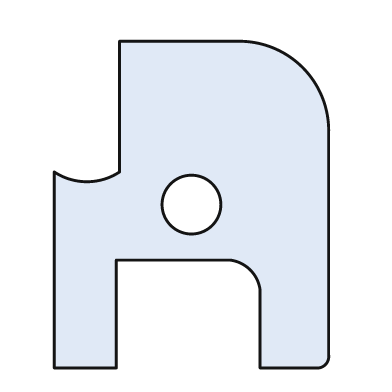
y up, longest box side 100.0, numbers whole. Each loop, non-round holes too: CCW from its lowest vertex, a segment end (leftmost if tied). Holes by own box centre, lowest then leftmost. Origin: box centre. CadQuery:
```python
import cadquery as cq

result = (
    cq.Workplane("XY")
    .moveTo(-42.0, -50.0)
    .lineTo(-23.0, -50.0)
    .lineTo(-23.0, -17.0)
    .lineTo(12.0, -17.0)
    .threePointArc((18.0, -20.0), (21.0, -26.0))
    .lineTo(21.0, -50.0)
    .lineTo(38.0, -50.0)
    .threePointArc((41.0, -49.0), (42.0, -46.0))
    .lineTo(42.0, 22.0)
    .threePointArc((34.0, 42.0), (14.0, 50.0))
    .lineTo(-22.0, 50.0)
    .lineTo(-22.0, 10.0)
    .threePointArc((-32.0, 7.0), (-42.0, 10.0))
    .close()
    .moveTo(0.0, 0.0)
    .circle(9.0)
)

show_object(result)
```